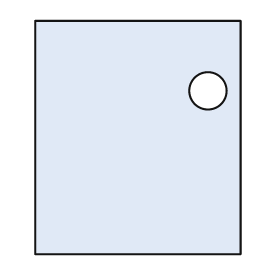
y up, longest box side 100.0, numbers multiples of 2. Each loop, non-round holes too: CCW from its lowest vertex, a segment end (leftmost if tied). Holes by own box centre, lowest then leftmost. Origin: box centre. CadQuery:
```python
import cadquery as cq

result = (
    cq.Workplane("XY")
    .moveTo(-44.0, -50.0)
    .lineTo(44.0, -50.0)
    .lineTo(44.0, 50.0)
    .lineTo(-44.0, 50.0)
    .close()
    .moveTo(30.0, 20.0)
    .circle(8.0)
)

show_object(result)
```